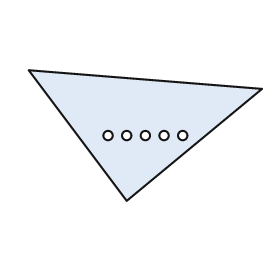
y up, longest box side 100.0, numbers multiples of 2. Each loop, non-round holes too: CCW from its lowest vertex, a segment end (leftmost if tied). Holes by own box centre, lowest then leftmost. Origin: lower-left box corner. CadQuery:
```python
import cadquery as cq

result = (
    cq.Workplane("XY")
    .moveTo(42.0, 0.0)
    .lineTo(100.0, 48.0)
    .lineTo(0.0, 56.0)
    .close()
    .moveTo(34.0, 28.0)
    .circle(2.0)
    .moveTo(42.0, 28.0)
    .circle(2.0)
    .moveTo(50.0, 28.0)
    .circle(2.0)
    .moveTo(58.0, 28.0)
    .circle(2.0)
    .moveTo(66.0, 28.0)
    .circle(2.0)
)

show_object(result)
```